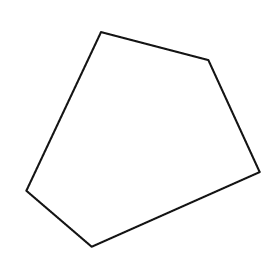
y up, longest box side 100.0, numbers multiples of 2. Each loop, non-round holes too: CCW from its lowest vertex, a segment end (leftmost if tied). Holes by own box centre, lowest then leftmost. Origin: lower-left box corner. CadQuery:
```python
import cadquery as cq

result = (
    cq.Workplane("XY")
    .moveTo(28.0, 0.0)
    .lineTo(100.0, 32.0)
    .lineTo(78.0, 80.0)
    .lineTo(32.0, 92.0)
    .lineTo(0.0, 24.0)
    .close()
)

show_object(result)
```